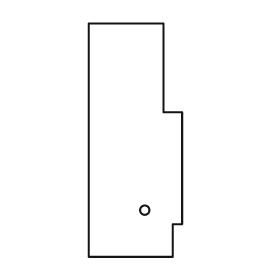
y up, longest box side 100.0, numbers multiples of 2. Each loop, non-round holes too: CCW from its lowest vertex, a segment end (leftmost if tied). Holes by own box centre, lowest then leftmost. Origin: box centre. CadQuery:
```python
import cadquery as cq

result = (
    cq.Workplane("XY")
    .moveTo(-20.0, -50.0)
    .lineTo(16.0, -50.0)
    .lineTo(16.0, -36.0)
    .lineTo(20.0, -36.0)
    .lineTo(20.0, 12.0)
    .lineTo(12.0, 12.0)
    .lineTo(12.0, 50.0)
    .lineTo(-20.0, 50.0)
    .close()
    .moveTo(4.0, -30.0)
    .circle(2.0)
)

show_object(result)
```